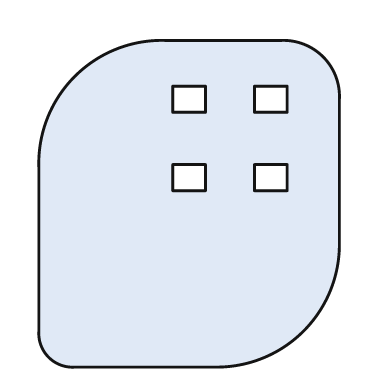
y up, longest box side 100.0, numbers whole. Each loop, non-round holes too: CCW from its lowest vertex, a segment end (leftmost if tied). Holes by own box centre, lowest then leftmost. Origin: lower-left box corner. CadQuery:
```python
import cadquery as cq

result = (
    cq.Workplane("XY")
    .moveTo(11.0, 0.0)
    .lineTo(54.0, 0.0)
    .threePointArc((81.0, 11.0), (92.0, 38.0))
    .lineTo(92.0, 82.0)
    .threePointArc((87.0, 95.0), (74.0, 100.0))
    .lineTo(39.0, 100.0)
    .threePointArc((11.0, 89.0), (0.0, 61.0))
    .lineTo(0.0, 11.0)
    .threePointArc((3.0, 3.0), (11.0, 0.0))
    .close()
    .moveTo(41.0, 54.0)
    .lineTo(51.0, 54.0)
    .lineTo(51.0, 62.0)
    .lineTo(41.0, 62.0)
    .close()
    .moveTo(66.0, 54.0)
    .lineTo(76.0, 54.0)
    .lineTo(76.0, 62.0)
    .lineTo(66.0, 62.0)
    .close()
    .moveTo(41.0, 78.0)
    .lineTo(51.0, 78.0)
    .lineTo(51.0, 86.0)
    .lineTo(41.0, 86.0)
    .close()
    .moveTo(66.0, 78.0)
    .lineTo(76.0, 78.0)
    .lineTo(76.0, 86.0)
    .lineTo(66.0, 86.0)
    .close()
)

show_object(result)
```